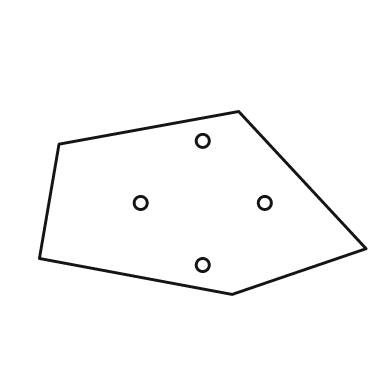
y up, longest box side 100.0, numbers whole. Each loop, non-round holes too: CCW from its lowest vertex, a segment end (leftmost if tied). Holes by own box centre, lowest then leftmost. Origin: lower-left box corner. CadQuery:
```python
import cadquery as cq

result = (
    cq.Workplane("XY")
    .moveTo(59.0, 0.0)
    .lineTo(100.0, 14.0)
    .lineTo(61.0, 56.0)
    .lineTo(6.0, 46.0)
    .lineTo(0.0, 11.0)
    .close()
    .moveTo(50.0, 9.0)
    .circle(2.0)
    .moveTo(31.0, 28.0)
    .circle(2.0)
    .moveTo(69.0, 28.0)
    .circle(2.0)
    .moveTo(50.0, 47.0)
    .circle(2.0)
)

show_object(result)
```